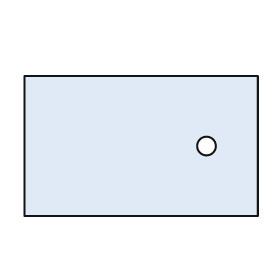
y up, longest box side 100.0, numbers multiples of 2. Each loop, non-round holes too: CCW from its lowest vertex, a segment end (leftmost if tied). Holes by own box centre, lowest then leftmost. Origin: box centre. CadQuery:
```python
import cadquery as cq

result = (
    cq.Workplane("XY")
    .moveTo(-50.0, -30.0)
    .lineTo(50.0, -30.0)
    .lineTo(50.0, 30.0)
    .lineTo(-50.0, 30.0)
    .close()
    .moveTo(28.0, 0.0)
    .circle(4.0)
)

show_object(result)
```